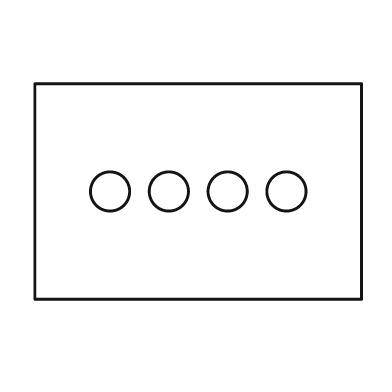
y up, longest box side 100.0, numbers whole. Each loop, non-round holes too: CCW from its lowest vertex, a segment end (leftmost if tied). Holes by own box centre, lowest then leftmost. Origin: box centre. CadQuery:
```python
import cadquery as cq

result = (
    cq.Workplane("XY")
    .moveTo(-50.0, -33.0)
    .lineTo(50.0, -33.0)
    .lineTo(50.0, 33.0)
    .lineTo(-50.0, 33.0)
    .close()
    .moveTo(-27.0, 0.0)
    .circle(6.0)
    .moveTo(-9.0, 0.0)
    .circle(6.0)
    .moveTo(9.0, 0.0)
    .circle(6.0)
    .moveTo(27.0, 0.0)
    .circle(6.0)
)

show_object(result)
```